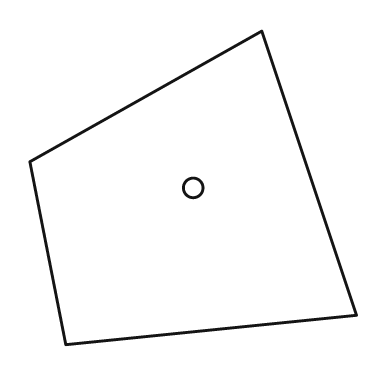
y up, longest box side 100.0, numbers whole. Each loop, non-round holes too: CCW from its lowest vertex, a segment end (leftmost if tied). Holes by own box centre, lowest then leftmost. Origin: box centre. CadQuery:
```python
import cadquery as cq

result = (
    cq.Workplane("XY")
    .moveTo(-39.0, -48.0)
    .lineTo(50.0, -39.0)
    .lineTo(21.0, 48.0)
    .lineTo(-50.0, 8.0)
    .close()
    .moveTo(0.0, 0.0)
    .circle(3.0)
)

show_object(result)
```